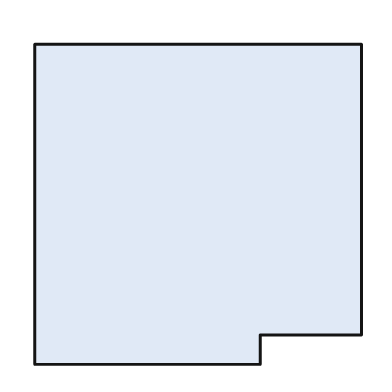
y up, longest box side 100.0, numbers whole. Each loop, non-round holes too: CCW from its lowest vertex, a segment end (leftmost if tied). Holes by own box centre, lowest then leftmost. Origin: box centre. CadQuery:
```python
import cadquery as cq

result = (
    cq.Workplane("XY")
    .moveTo(-50.0, -49.0)
    .lineTo(19.0, -49.0)
    .lineTo(19.0, -40.0)
    .lineTo(50.0, -40.0)
    .lineTo(50.0, 49.0)
    .lineTo(-50.0, 49.0)
    .close()
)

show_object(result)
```